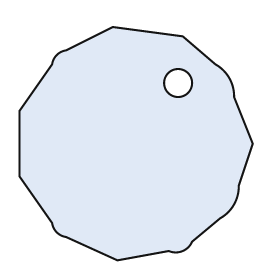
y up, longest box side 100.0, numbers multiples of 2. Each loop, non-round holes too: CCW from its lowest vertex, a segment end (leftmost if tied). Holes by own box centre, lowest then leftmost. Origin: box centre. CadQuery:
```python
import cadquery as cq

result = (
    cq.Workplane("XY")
    .moveTo(-8.0, -50.0)
    .lineTo(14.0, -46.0)
    .threePointArc((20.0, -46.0), (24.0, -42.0))
    .lineTo(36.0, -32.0)
    .threePointArc((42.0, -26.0), (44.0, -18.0))
    .lineTo(50.0, 0.0)
    .lineTo(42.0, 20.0)
    .threePointArc((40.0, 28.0), (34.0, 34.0))
    .lineTo(20.0, 46.0)
    .lineTo(-10.0, 50.0)
    .lineTo(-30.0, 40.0)
    .threePointArc((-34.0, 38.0), (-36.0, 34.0))
    .lineTo(-50.0, 14.0)
    .lineTo(-50.0, -14.0)
    .lineTo(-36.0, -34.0)
    .threePointArc((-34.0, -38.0), (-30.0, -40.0))
    .close()
    .moveTo(18.0, 26.0)
    .circle(6.0)
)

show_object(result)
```